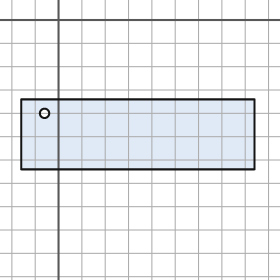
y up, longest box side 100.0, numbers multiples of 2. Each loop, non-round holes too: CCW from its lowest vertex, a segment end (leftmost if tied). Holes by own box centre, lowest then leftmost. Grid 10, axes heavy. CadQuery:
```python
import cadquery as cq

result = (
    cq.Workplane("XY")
    .moveTo(-16.0, -64.0)
    .lineTo(84.0, -64.0)
    .lineTo(84.0, -34.0)
    .lineTo(-16.0, -34.0)
    .close()
    .moveTo(-6.0, -40.0)
    .circle(2.0)
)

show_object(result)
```